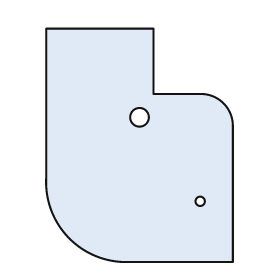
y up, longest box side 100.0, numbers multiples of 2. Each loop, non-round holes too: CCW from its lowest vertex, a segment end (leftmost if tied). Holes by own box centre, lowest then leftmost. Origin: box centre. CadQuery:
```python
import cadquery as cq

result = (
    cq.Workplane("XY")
    .moveTo(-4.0, -50.0)
    .lineTo(40.0, -50.0)
    .lineTo(40.0, 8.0)
    .threePointArc((36.0, 18.0), (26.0, 22.0))
    .lineTo(6.0, 22.0)
    .lineTo(6.0, 50.0)
    .lineTo(-40.0, 50.0)
    .lineTo(-40.0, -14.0)
    .threePointArc((-30.0, -40.0), (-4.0, -50.0))
    .close()
    .moveTo(26.0, -24.0)
    .circle(2.0)
    .moveTo(0.0, 12.0)
    .circle(4.0)
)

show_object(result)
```